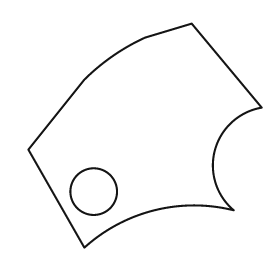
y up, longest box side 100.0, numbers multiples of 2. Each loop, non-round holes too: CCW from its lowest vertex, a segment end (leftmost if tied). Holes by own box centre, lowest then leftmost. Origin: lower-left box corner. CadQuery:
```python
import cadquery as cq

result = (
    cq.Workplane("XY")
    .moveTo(24.0, 0.0)
    .threePointArc((54.0, 16.0), (88.0, 16.0))
    .threePointArc((80.0, 42.0), (100.0, 60.0))
    .lineTo(70.0, 96.0)
    .lineTo(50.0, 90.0)
    .threePointArc((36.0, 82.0), (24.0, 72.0))
    .lineTo(0.0, 42.0)
    .close()
    .moveTo(28.0, 24.0)
    .circle(10.0)
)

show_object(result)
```